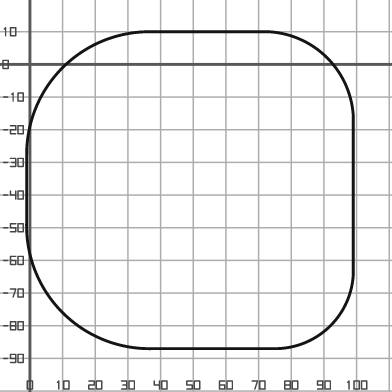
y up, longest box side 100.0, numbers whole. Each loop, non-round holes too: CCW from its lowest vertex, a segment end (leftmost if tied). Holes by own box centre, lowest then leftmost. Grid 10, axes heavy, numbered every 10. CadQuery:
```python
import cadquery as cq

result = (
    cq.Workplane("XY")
    .moveTo(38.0, -87.0)
    .lineTo(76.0, -87.0)
    .threePointArc((92.0, -80.0), (99.0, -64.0))
    .lineTo(99.0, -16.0)
    .threePointArc((91.0, 2.0), (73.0, 10.0))
    .lineTo(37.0, 10.0)
    .threePointArc((10.0, -1.0), (-1.0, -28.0))
    .lineTo(-1.0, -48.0)
    .threePointArc((10.0, -76.0), (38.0, -87.0))
    .close()
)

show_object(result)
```